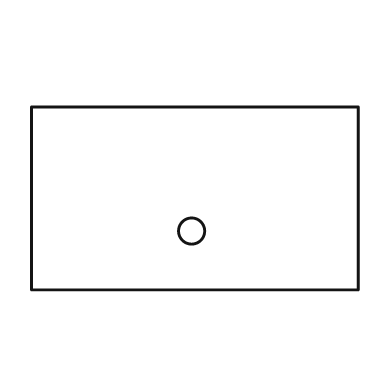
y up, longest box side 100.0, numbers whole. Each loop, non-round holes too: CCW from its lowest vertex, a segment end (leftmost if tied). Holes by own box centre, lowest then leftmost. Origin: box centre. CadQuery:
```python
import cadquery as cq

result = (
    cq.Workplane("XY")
    .moveTo(-50.0, -28.0)
    .lineTo(50.0, -28.0)
    .lineTo(50.0, 28.0)
    .lineTo(-50.0, 28.0)
    .close()
    .moveTo(-1.0, -10.0)
    .circle(4.0)
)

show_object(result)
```